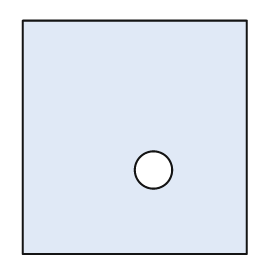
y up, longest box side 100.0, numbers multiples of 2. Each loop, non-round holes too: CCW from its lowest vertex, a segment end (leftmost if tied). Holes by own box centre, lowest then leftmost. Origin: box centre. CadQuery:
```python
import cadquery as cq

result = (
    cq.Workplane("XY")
    .moveTo(-48.0, -50.0)
    .lineTo(48.0, -50.0)
    .lineTo(48.0, 50.0)
    .lineTo(-48.0, 50.0)
    .close()
    .moveTo(8.0, -14.0)
    .circle(8.0)
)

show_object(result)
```